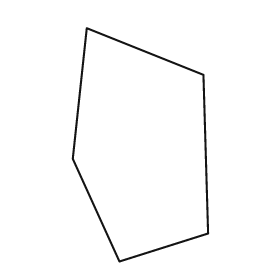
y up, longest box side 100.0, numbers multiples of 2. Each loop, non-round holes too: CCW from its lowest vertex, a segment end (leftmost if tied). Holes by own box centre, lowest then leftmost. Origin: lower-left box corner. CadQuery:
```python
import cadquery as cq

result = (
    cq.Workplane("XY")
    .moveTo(20.0, 0.0)
    .lineTo(58.0, 12.0)
    .lineTo(56.0, 80.0)
    .lineTo(6.0, 100.0)
    .lineTo(0.0, 44.0)
    .close()
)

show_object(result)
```